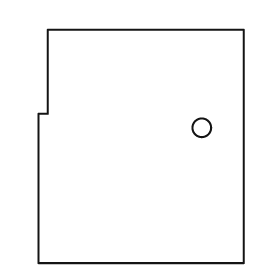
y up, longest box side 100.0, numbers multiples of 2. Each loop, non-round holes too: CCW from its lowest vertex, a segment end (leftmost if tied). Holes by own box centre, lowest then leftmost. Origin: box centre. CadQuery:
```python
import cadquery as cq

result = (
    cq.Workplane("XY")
    .moveTo(-44.0, -50.0)
    .lineTo(44.0, -50.0)
    .lineTo(44.0, 50.0)
    .lineTo(-40.0, 50.0)
    .lineTo(-40.0, 14.0)
    .lineTo(-44.0, 14.0)
    .close()
    .moveTo(26.0, 8.0)
    .circle(4.0)
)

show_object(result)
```